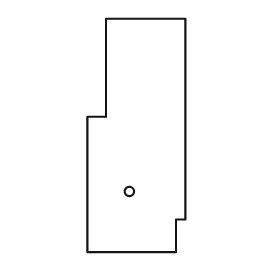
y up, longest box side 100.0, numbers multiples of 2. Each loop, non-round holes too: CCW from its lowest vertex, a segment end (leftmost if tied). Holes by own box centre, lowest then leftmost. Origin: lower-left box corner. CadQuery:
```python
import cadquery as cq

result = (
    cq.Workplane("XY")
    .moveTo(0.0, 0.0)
    .lineTo(38.0, 0.0)
    .lineTo(38.0, 14.0)
    .lineTo(42.0, 14.0)
    .lineTo(42.0, 100.0)
    .lineTo(8.0, 100.0)
    .lineTo(8.0, 58.0)
    .lineTo(0.0, 58.0)
    .close()
    .moveTo(18.0, 26.0)
    .circle(2.0)
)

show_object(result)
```